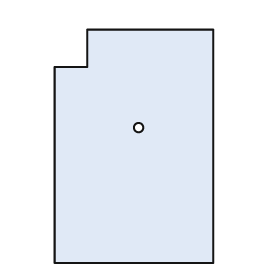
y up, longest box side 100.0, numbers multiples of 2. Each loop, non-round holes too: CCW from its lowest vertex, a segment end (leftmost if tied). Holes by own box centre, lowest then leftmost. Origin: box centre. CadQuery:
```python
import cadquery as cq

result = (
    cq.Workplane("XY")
    .moveTo(-34.0, -50.0)
    .lineTo(34.0, -50.0)
    .lineTo(34.0, 50.0)
    .lineTo(-20.0, 50.0)
    .lineTo(-20.0, 34.0)
    .lineTo(-34.0, 34.0)
    .close()
    .moveTo(2.0, 8.0)
    .circle(2.0)
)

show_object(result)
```